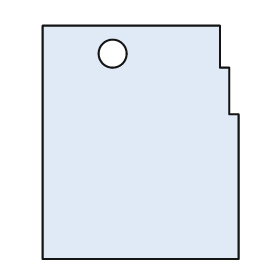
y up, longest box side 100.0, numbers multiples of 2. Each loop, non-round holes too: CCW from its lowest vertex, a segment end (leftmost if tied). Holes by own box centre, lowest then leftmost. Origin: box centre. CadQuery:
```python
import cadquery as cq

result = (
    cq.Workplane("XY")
    .moveTo(-42.0, -50.0)
    .lineTo(42.0, -50.0)
    .lineTo(42.0, 12.0)
    .lineTo(38.0, 12.0)
    .lineTo(38.0, 32.0)
    .lineTo(34.0, 32.0)
    .lineTo(34.0, 50.0)
    .lineTo(-42.0, 50.0)
    .close()
    .moveTo(-12.0, 38.0)
    .circle(6.0)
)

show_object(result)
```